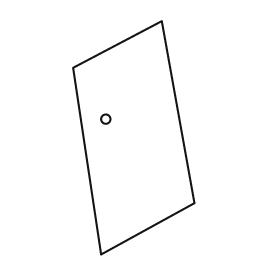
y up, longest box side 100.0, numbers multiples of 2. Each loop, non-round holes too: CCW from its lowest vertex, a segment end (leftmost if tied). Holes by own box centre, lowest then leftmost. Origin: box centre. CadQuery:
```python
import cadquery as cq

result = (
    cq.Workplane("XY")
    .moveTo(-14.0, -50.0)
    .lineTo(26.0, -28.0)
    .lineTo(12.0, 50.0)
    .lineTo(-26.0, 30.0)
    .close()
    .moveTo(-12.0, 8.0)
    .circle(2.0)
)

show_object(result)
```